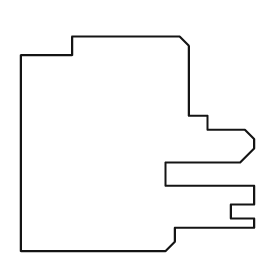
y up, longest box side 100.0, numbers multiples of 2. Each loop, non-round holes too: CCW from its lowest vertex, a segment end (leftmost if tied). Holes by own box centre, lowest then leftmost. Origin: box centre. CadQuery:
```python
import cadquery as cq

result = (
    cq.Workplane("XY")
    .moveTo(-50.0, -46.0)
    .lineTo(12.0, -46.0)
    .lineTo(16.0, -42.0)
    .lineTo(16.0, -36.0)
    .lineTo(50.0, -36.0)
    .lineTo(50.0, -32.0)
    .lineTo(40.0, -32.0)
    .lineTo(40.0, -26.0)
    .lineTo(50.0, -26.0)
    .lineTo(50.0, -18.0)
    .lineTo(12.0, -18.0)
    .lineTo(12.0, -8.0)
    .lineTo(44.0, -8.0)
    .lineTo(50.0, -2.0)
    .lineTo(50.0, 2.0)
    .lineTo(46.0, 6.0)
    .lineTo(30.0, 6.0)
    .lineTo(30.0, 12.0)
    .lineTo(22.0, 12.0)
    .lineTo(22.0, 42.0)
    .lineTo(18.0, 46.0)
    .lineTo(-28.0, 46.0)
    .lineTo(-28.0, 38.0)
    .lineTo(-50.0, 38.0)
    .close()
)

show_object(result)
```